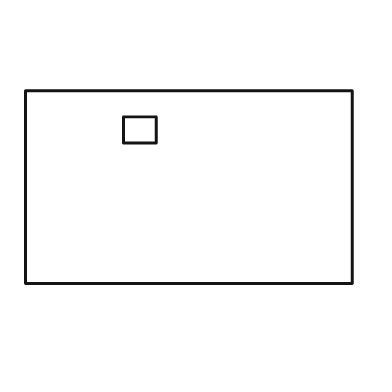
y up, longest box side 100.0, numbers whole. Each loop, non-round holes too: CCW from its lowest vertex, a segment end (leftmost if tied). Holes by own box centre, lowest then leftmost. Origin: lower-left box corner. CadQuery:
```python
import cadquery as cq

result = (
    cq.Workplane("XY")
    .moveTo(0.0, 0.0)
    .lineTo(100.0, 0.0)
    .lineTo(100.0, 59.0)
    .lineTo(0.0, 59.0)
    .close()
    .moveTo(30.0, 43.0)
    .lineTo(40.0, 43.0)
    .lineTo(40.0, 51.0)
    .lineTo(30.0, 51.0)
    .close()
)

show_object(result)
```